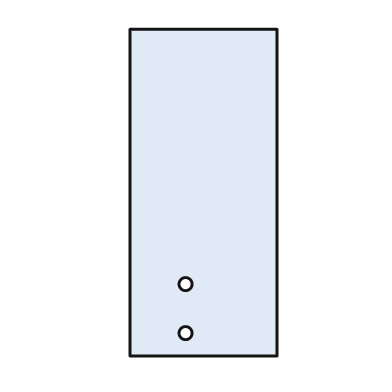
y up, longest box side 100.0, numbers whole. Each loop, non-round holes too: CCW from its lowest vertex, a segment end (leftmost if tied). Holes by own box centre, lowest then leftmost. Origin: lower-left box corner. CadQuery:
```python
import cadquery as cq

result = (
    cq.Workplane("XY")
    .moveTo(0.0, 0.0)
    .lineTo(45.0, 0.0)
    .lineTo(45.0, 100.0)
    .lineTo(0.0, 100.0)
    .close()
    .moveTo(17.0, 7.0)
    .circle(2.0)
    .moveTo(17.0, 22.0)
    .circle(2.0)
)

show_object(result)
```